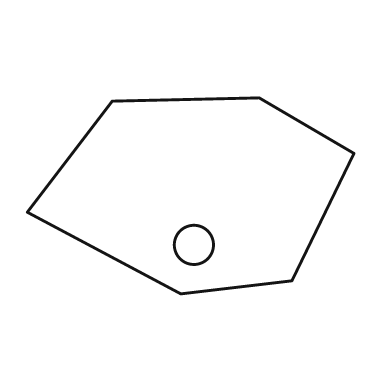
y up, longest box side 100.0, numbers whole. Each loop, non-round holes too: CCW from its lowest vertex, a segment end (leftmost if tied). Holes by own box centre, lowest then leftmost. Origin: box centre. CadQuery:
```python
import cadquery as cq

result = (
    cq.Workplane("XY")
    .moveTo(-3.0, -30.0)
    .lineTo(31.0, -26.0)
    .lineTo(50.0, 13.0)
    .lineTo(21.0, 30.0)
    .lineTo(-24.0, 29.0)
    .lineTo(-50.0, -5.0)
    .close()
    .moveTo(1.0, -15.0)
    .circle(6.0)
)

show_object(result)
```